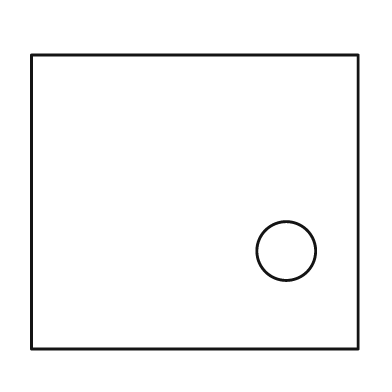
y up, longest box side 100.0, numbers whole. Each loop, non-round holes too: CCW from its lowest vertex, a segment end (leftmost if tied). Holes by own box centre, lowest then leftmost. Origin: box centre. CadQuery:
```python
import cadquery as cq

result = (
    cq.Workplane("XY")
    .moveTo(-50.0, -45.0)
    .lineTo(50.0, -45.0)
    .lineTo(50.0, 45.0)
    .lineTo(-50.0, 45.0)
    .close()
    .moveTo(28.0, -15.0)
    .circle(9.0)
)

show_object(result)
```